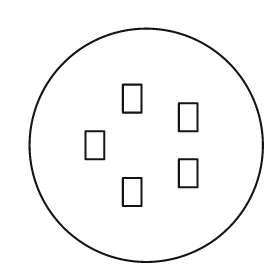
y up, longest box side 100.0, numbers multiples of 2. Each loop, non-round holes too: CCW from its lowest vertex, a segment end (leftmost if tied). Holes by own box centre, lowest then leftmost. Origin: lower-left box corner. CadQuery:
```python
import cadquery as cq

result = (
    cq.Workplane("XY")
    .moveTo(50.0, 50.0)
    .circle(50.0)
    .moveTo(40.0, 24.0)
    .lineTo(48.0, 24.0)
    .lineTo(48.0, 36.0)
    .lineTo(40.0, 36.0)
    .close()
    .moveTo(64.0, 32.0)
    .lineTo(72.0, 32.0)
    .lineTo(72.0, 44.0)
    .lineTo(64.0, 44.0)
    .close()
    .moveTo(24.0, 44.0)
    .lineTo(32.0, 44.0)
    .lineTo(32.0, 56.0)
    .lineTo(24.0, 56.0)
    .close()
    .moveTo(64.0, 56.0)
    .lineTo(72.0, 56.0)
    .lineTo(72.0, 68.0)
    .lineTo(64.0, 68.0)
    .close()
    .moveTo(40.0, 64.0)
    .lineTo(48.0, 64.0)
    .lineTo(48.0, 76.0)
    .lineTo(40.0, 76.0)
    .close()
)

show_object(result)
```